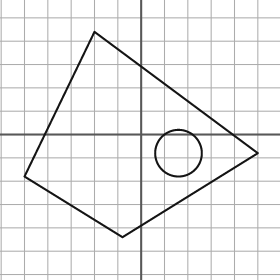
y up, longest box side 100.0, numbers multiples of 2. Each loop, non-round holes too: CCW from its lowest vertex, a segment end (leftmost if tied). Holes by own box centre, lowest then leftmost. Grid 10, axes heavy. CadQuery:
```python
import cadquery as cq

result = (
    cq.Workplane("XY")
    .moveTo(-8.0, -44.0)
    .lineTo(50.0, -8.0)
    .lineTo(-20.0, 44.0)
    .lineTo(-50.0, -18.0)
    .close()
    .moveTo(16.0, -8.0)
    .circle(10.0)
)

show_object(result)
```